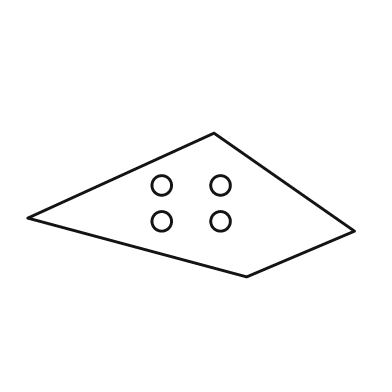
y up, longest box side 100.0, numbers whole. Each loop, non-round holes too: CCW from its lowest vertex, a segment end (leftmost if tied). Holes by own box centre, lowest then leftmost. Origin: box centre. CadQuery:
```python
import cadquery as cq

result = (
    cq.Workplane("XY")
    .moveTo(17.0, -22.0)
    .lineTo(50.0, -8.0)
    .lineTo(7.0, 22.0)
    .lineTo(-50.0, -4.0)
    .close()
    .moveTo(-9.0, -5.0)
    .circle(3.0)
    .moveTo(9.0, -5.0)
    .circle(3.0)
    .moveTo(-9.0, 6.0)
    .circle(3.0)
    .moveTo(9.0, 6.0)
    .circle(3.0)
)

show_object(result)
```